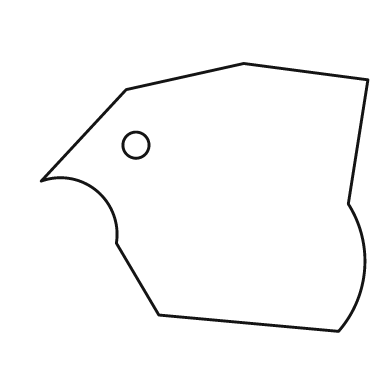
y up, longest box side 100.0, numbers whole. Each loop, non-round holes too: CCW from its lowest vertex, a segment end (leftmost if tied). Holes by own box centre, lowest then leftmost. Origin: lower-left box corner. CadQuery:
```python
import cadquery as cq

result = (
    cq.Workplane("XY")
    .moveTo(91.0, 0.0)
    .threePointArc((99.0, 19.0), (94.0, 39.0))
    .lineTo(100.0, 77.0)
    .lineTo(62.0, 82.0)
    .lineTo(26.0, 74.0)
    .lineTo(0.0, 46.0)
    .threePointArc((17.0, 43.0), (23.0, 27.0))
    .lineTo(36.0, 5.0)
    .close()
    .moveTo(29.0, 57.0)
    .circle(4.0)
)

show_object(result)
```